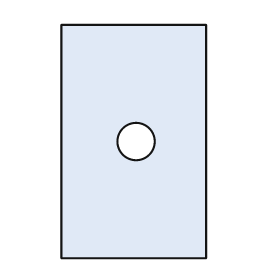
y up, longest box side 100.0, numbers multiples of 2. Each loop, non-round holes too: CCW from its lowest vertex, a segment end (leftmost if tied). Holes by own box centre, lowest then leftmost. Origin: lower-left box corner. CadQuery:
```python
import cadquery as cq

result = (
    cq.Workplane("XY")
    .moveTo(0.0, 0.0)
    .lineTo(62.0, 0.0)
    .lineTo(62.0, 100.0)
    .lineTo(0.0, 100.0)
    .close()
    .moveTo(32.0, 50.0)
    .circle(8.0)
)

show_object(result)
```